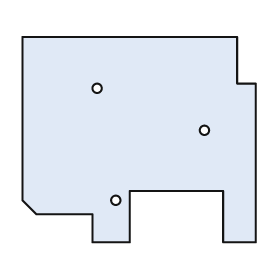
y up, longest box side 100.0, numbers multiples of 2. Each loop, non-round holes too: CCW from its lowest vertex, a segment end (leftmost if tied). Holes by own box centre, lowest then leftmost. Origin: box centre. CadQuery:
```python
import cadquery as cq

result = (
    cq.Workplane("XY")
    .moveTo(-20.0, -44.0)
    .lineTo(-4.0, -44.0)
    .lineTo(-4.0, -22.0)
    .lineTo(36.0, -22.0)
    .lineTo(36.0, -44.0)
    .lineTo(50.0, -44.0)
    .lineTo(50.0, 24.0)
    .lineTo(42.0, 24.0)
    .lineTo(42.0, 44.0)
    .lineTo(-50.0, 44.0)
    .lineTo(-50.0, -26.0)
    .lineTo(-44.0, -32.0)
    .lineTo(-20.0, -32.0)
    .close()
    .moveTo(-10.0, -26.0)
    .circle(2.0)
    .moveTo(28.0, 4.0)
    .circle(2.0)
    .moveTo(-18.0, 22.0)
    .circle(2.0)
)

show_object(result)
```